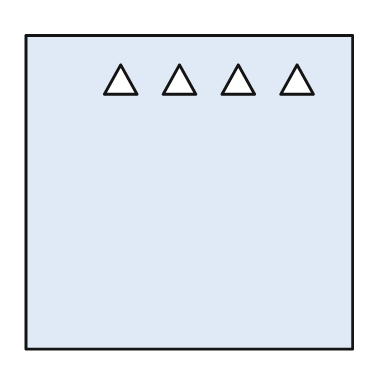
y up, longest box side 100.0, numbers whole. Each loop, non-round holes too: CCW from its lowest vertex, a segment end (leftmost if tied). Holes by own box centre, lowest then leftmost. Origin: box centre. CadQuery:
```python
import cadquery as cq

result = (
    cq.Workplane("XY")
    .moveTo(-50.0, -48.0)
    .lineTo(50.0, -48.0)
    .lineTo(50.0, 48.0)
    .lineTo(-50.0, 48.0)
    .close()
    .moveTo(-26.0, 30.0)
    .lineTo(-16.0, 30.0)
    .lineTo(-21.0, 39.0)
    .close()
    .moveTo(-8.0, 30.0)
    .lineTo(2.0, 30.0)
    .lineTo(-3.0, 39.0)
    .close()
    .moveTo(10.0, 30.0)
    .lineTo(20.0, 30.0)
    .lineTo(15.0, 39.0)
    .close()
    .moveTo(28.0, 30.0)
    .lineTo(38.0, 30.0)
    .lineTo(33.0, 39.0)
    .close()
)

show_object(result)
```